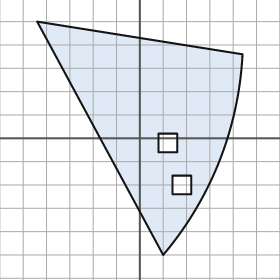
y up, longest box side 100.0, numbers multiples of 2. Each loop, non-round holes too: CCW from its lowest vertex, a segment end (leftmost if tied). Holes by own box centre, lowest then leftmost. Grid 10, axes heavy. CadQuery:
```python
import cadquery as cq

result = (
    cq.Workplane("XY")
    .moveTo(10.0, -50.0)
    .threePointArc((34.0, -10.0), (44.0, 36.0))
    .lineTo(-44.0, 50.0)
    .close()
    .moveTo(14.0, -24.0)
    .lineTo(22.0, -24.0)
    .lineTo(22.0, -16.0)
    .lineTo(14.0, -16.0)
    .close()
    .moveTo(8.0, -6.0)
    .lineTo(16.0, -6.0)
    .lineTo(16.0, 2.0)
    .lineTo(8.0, 2.0)
    .close()
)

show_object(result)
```